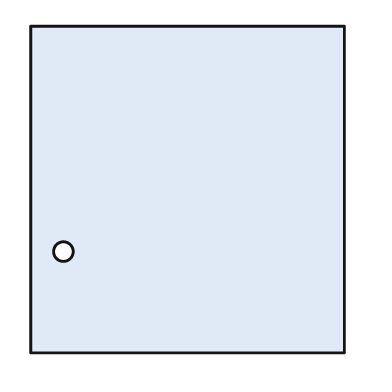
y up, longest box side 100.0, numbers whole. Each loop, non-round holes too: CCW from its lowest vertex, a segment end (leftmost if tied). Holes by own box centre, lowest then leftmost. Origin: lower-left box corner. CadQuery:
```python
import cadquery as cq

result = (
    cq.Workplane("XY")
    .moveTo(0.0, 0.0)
    .lineTo(96.0, 0.0)
    .lineTo(96.0, 100.0)
    .lineTo(0.0, 100.0)
    .close()
    .moveTo(10.0, 31.0)
    .circle(3.0)
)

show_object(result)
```